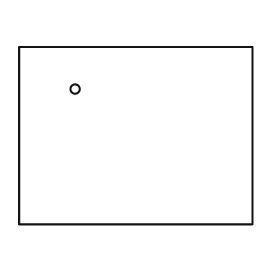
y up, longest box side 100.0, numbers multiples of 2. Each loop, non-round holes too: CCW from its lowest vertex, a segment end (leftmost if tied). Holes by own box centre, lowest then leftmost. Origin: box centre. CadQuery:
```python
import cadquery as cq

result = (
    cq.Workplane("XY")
    .moveTo(-50.0, -38.0)
    .lineTo(50.0, -38.0)
    .lineTo(50.0, 38.0)
    .lineTo(-50.0, 38.0)
    .close()
    .moveTo(-26.0, 20.0)
    .circle(2.0)
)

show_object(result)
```